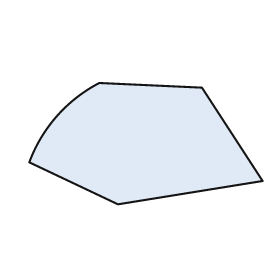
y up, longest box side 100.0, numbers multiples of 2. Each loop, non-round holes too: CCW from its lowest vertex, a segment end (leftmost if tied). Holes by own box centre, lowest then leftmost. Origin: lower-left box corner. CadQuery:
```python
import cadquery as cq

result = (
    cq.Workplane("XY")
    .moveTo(38.0, 0.0)
    .lineTo(100.0, 10.0)
    .lineTo(74.0, 50.0)
    .lineTo(30.0, 52.0)
    .threePointArc((12.0, 38.0), (0.0, 18.0))
    .close()
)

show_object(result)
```